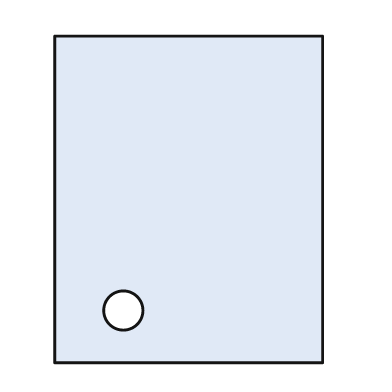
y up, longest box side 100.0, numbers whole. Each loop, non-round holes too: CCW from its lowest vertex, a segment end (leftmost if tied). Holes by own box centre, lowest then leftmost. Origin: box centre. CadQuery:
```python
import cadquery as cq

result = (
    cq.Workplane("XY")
    .moveTo(-41.0, -50.0)
    .lineTo(41.0, -50.0)
    .lineTo(41.0, 50.0)
    .lineTo(-41.0, 50.0)
    .close()
    .moveTo(-20.0, -34.0)
    .circle(6.0)
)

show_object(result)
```